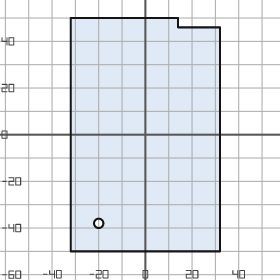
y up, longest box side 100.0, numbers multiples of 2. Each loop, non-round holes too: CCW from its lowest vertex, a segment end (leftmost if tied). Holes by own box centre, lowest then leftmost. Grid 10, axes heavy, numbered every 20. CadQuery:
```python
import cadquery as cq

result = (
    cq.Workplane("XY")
    .moveTo(-32.0, -50.0)
    .lineTo(32.0, -50.0)
    .lineTo(32.0, 46.0)
    .lineTo(14.0, 46.0)
    .lineTo(14.0, 50.0)
    .lineTo(-32.0, 50.0)
    .close()
    .moveTo(-20.0, -38.0)
    .circle(2.0)
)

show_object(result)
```